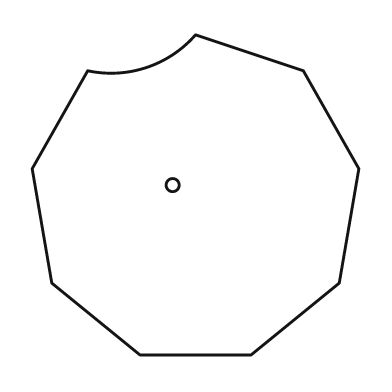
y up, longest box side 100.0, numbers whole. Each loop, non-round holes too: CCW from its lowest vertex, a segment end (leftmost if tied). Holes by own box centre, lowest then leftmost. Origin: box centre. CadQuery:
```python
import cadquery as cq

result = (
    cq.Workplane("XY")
    .moveTo(-17.0, -49.0)
    .lineTo(17.0, -49.0)
    .lineTo(44.0, -27.0)
    .lineTo(50.0, 8.0)
    .lineTo(33.0, 38.0)
    .lineTo(0.0, 49.0)
    .threePointArc((-15.0, 39.0), (-33.0, 38.0))
    .lineTo(-50.0, 8.0)
    .lineTo(-44.0, -27.0)
    .close()
    .moveTo(-7.0, 3.0)
    .circle(2.0)
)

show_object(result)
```